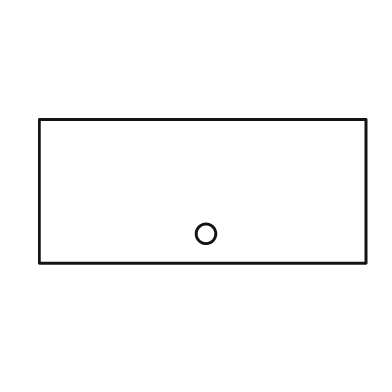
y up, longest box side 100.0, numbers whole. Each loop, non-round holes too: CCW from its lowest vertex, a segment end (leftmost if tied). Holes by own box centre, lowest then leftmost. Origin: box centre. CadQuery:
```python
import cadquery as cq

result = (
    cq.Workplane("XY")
    .moveTo(-50.0, -22.0)
    .lineTo(50.0, -22.0)
    .lineTo(50.0, 22.0)
    .lineTo(-50.0, 22.0)
    .close()
    .moveTo(1.0, -13.0)
    .circle(3.0)
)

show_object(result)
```